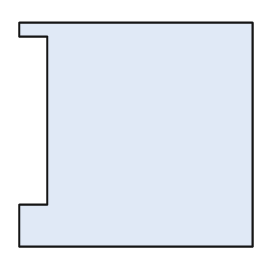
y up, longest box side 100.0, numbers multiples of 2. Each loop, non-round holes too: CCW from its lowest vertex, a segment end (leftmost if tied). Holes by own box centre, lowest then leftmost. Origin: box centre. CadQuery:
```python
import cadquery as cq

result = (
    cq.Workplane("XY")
    .moveTo(-50.0, -48.0)
    .lineTo(50.0, -48.0)
    .lineTo(50.0, 48.0)
    .lineTo(-50.0, 48.0)
    .lineTo(-50.0, 42.0)
    .lineTo(-38.0, 42.0)
    .lineTo(-38.0, -30.0)
    .lineTo(-50.0, -30.0)
    .close()
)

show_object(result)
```